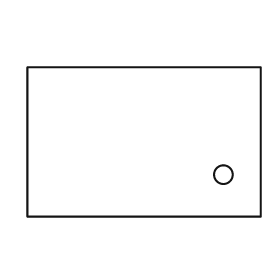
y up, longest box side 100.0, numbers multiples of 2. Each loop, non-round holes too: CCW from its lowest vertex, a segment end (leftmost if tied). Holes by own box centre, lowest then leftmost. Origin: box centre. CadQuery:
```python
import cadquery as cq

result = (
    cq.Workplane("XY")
    .moveTo(-50.0, -32.0)
    .lineTo(50.0, -32.0)
    .lineTo(50.0, 32.0)
    .lineTo(-50.0, 32.0)
    .close()
    .moveTo(34.0, -14.0)
    .circle(4.0)
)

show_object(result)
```